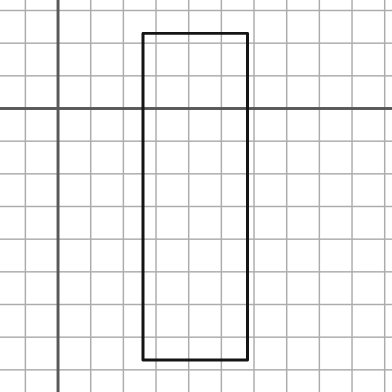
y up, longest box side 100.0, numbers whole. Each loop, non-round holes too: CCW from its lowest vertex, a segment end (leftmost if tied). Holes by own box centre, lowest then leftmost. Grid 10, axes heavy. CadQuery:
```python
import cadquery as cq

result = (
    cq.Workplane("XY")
    .moveTo(26.0, -77.0)
    .lineTo(58.0, -77.0)
    .lineTo(58.0, 23.0)
    .lineTo(26.0, 23.0)
    .close()
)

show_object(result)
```